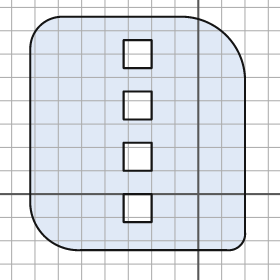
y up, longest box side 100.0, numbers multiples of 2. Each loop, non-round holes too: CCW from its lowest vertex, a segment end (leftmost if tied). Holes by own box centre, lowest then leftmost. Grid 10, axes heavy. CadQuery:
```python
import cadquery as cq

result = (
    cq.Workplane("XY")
    .moveTo(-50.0, -24.0)
    .lineTo(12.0, -24.0)
    .threePointArc((18.0, -22.0), (20.0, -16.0))
    .lineTo(20.0, 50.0)
    .threePointArc((12.0, 68.0), (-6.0, 76.0))
    .lineTo(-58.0, 76.0)
    .threePointArc((-68.0, 72.0), (-72.0, 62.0))
    .lineTo(-72.0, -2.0)
    .threePointArc((-66.0, -18.0), (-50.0, -24.0))
    .close()
    .moveTo(-32.0, -12.0)
    .lineTo(-20.0, -12.0)
    .lineTo(-20.0, 0.0)
    .lineTo(-32.0, 0.0)
    .close()
    .moveTo(-32.0, 10.0)
    .lineTo(-20.0, 10.0)
    .lineTo(-20.0, 22.0)
    .lineTo(-32.0, 22.0)
    .close()
    .moveTo(-32.0, 32.0)
    .lineTo(-20.0, 32.0)
    .lineTo(-20.0, 44.0)
    .lineTo(-32.0, 44.0)
    .close()
    .moveTo(-32.0, 54.0)
    .lineTo(-20.0, 54.0)
    .lineTo(-20.0, 66.0)
    .lineTo(-32.0, 66.0)
    .close()
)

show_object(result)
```